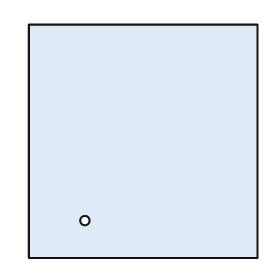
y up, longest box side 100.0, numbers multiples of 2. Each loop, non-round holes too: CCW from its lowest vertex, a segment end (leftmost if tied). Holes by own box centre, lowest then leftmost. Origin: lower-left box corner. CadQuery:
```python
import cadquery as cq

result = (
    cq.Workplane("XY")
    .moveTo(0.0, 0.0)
    .lineTo(98.0, 0.0)
    .lineTo(98.0, 100.0)
    .lineTo(0.0, 100.0)
    .close()
    .moveTo(24.0, 16.0)
    .circle(2.0)
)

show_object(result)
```